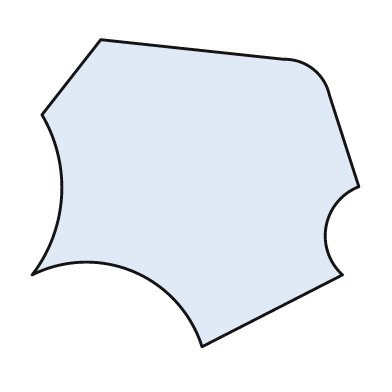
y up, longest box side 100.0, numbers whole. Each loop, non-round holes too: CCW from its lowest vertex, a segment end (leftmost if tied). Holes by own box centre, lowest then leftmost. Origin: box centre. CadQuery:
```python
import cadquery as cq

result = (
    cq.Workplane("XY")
    .moveTo(2.0, -47.0)
    .lineTo(45.0, -25.0)
    .threePointArc((40.0, -10.0), (50.0, 2.0))
    .lineTo(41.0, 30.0)
    .threePointArc((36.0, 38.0), (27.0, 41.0))
    .lineTo(-29.0, 47.0)
    .lineTo(-47.0, 24.0)
    .threePointArc((-41.0, -1.0), (-50.0, -25.0))
    .threePointArc((-19.0, -24.0), (2.0, -47.0))
    .close()
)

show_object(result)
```